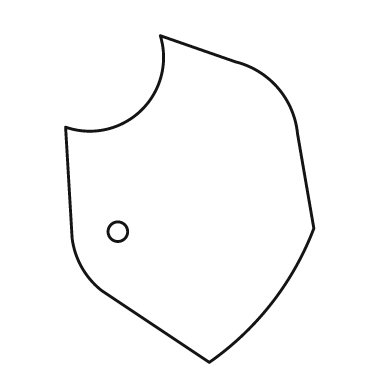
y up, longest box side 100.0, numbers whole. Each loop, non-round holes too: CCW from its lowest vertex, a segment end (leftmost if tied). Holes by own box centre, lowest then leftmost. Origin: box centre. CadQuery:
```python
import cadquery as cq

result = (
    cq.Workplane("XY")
    .moveTo(6.0, -50.0)
    .threePointArc((25.0, -32.0), (38.0, -9.0))
    .lineTo(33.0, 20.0)
    .threePointArc((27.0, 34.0), (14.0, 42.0))
    .lineTo(-9.0, 50.0)
    .threePointArc((-15.0, 27.0), (-38.0, 22.0))
    .lineTo(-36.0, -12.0)
    .threePointArc((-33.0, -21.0), (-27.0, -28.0))
    .close()
    .moveTo(-22.0, -10.0)
    .circle(3.0)
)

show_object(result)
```